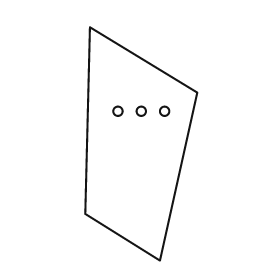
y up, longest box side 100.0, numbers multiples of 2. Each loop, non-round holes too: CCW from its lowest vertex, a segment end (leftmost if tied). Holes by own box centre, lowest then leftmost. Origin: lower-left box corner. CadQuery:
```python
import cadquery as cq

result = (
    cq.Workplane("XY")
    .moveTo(32.0, 0.0)
    .lineTo(48.0, 72.0)
    .lineTo(2.0, 100.0)
    .lineTo(0.0, 20.0)
    .close()
    .moveTo(14.0, 64.0)
    .circle(2.0)
    .moveTo(24.0, 64.0)
    .circle(2.0)
    .moveTo(34.0, 64.0)
    .circle(2.0)
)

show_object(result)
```